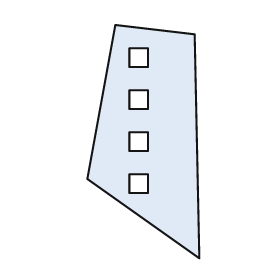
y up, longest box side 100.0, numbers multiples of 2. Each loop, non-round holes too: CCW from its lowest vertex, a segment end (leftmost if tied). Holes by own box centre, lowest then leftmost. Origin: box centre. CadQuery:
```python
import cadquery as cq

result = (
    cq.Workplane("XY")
    .moveTo(24.0, -50.0)
    .lineTo(22.0, 46.0)
    .lineTo(-12.0, 50.0)
    .lineTo(-24.0, -16.0)
    .close()
    .moveTo(-6.0, -22.0)
    .lineTo(2.0, -22.0)
    .lineTo(2.0, -14.0)
    .lineTo(-6.0, -14.0)
    .close()
    .moveTo(-6.0, -4.0)
    .lineTo(2.0, -4.0)
    .lineTo(2.0, 4.0)
    .lineTo(-6.0, 4.0)
    .close()
    .moveTo(-6.0, 14.0)
    .lineTo(2.0, 14.0)
    .lineTo(2.0, 22.0)
    .lineTo(-6.0, 22.0)
    .close()
    .moveTo(-6.0, 32.0)
    .lineTo(2.0, 32.0)
    .lineTo(2.0, 40.0)
    .lineTo(-6.0, 40.0)
    .close()
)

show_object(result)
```